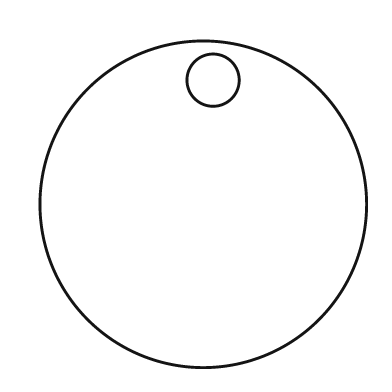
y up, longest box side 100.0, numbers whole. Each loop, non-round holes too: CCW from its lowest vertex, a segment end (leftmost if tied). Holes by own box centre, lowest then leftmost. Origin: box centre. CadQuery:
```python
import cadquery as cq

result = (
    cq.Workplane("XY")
    .moveTo(0.0, 0.0)
    .circle(50.0)
    .moveTo(3.0, 38.0)
    .circle(8.0)
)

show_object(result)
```